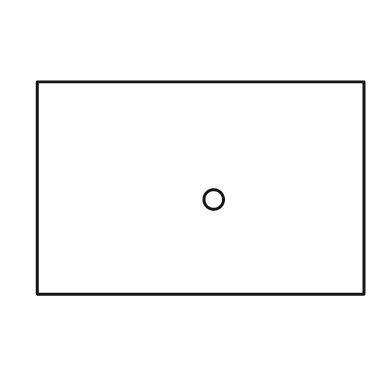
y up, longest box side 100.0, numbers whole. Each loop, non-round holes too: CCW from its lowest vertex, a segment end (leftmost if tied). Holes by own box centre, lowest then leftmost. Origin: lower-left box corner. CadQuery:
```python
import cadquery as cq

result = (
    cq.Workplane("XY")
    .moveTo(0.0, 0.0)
    .lineTo(100.0, 0.0)
    .lineTo(100.0, 65.0)
    .lineTo(0.0, 65.0)
    .close()
    .moveTo(54.0, 29.0)
    .circle(3.0)
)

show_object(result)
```